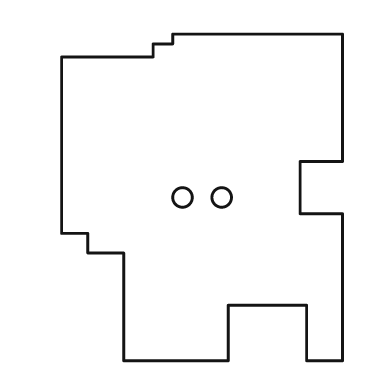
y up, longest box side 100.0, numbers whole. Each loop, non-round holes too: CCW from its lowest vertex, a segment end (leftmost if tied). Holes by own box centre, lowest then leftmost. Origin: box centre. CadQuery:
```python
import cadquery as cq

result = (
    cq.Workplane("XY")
    .moveTo(-24.0, -50.0)
    .lineTo(8.0, -50.0)
    .lineTo(8.0, -33.0)
    .lineTo(32.0, -33.0)
    .lineTo(32.0, -50.0)
    .lineTo(43.0, -50.0)
    .lineTo(43.0, -5.0)
    .lineTo(30.0, -5.0)
    .lineTo(30.0, 11.0)
    .lineTo(43.0, 11.0)
    .lineTo(43.0, 50.0)
    .lineTo(-9.0, 50.0)
    .lineTo(-9.0, 47.0)
    .lineTo(-15.0, 47.0)
    .lineTo(-15.0, 43.0)
    .lineTo(-43.0, 43.0)
    .lineTo(-43.0, -11.0)
    .lineTo(-35.0, -11.0)
    .lineTo(-35.0, -17.0)
    .lineTo(-24.0, -17.0)
    .close()
    .moveTo(-6.0, 0.0)
    .circle(3.0)
    .moveTo(6.0, 0.0)
    .circle(3.0)
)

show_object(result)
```